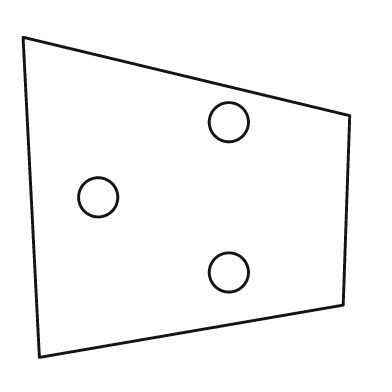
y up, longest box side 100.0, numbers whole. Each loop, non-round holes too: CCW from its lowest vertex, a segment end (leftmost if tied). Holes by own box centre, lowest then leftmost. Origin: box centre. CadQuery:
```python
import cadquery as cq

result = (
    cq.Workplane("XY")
    .moveTo(-45.0, -49.0)
    .lineTo(48.0, -33.0)
    .lineTo(50.0, 25.0)
    .lineTo(-50.0, 49.0)
    .close()
    .moveTo(13.0, -23.0)
    .circle(6.0)
    .moveTo(-27.0, 0.0)
    .circle(6.0)
    .moveTo(13.0, 23.0)
    .circle(6.0)
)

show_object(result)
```